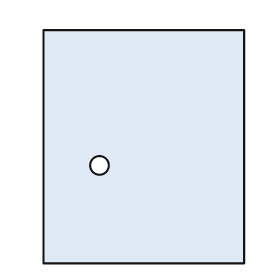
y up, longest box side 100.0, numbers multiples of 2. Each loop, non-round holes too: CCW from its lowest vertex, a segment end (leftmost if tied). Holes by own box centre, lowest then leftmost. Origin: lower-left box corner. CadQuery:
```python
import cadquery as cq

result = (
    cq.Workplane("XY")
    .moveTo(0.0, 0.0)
    .lineTo(86.0, 0.0)
    .lineTo(86.0, 100.0)
    .lineTo(0.0, 100.0)
    .close()
    .moveTo(24.0, 42.0)
    .circle(4.0)
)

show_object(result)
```